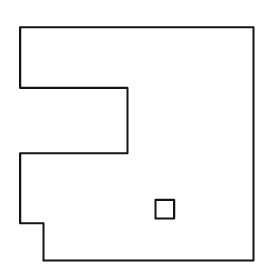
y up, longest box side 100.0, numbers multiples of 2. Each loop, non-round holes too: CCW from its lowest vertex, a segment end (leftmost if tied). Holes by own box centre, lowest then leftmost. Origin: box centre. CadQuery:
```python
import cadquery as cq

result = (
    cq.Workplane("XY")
    .moveTo(-40.0, -50.0)
    .lineTo(50.0, -50.0)
    .lineTo(50.0, 50.0)
    .lineTo(-50.0, 50.0)
    .lineTo(-50.0, 24.0)
    .lineTo(-4.0, 24.0)
    .lineTo(-4.0, -4.0)
    .lineTo(-50.0, -4.0)
    .lineTo(-50.0, -34.0)
    .lineTo(-40.0, -34.0)
    .close()
    .moveTo(8.0, -32.0)
    .lineTo(16.0, -32.0)
    .lineTo(16.0, -24.0)
    .lineTo(8.0, -24.0)
    .close()
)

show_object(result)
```